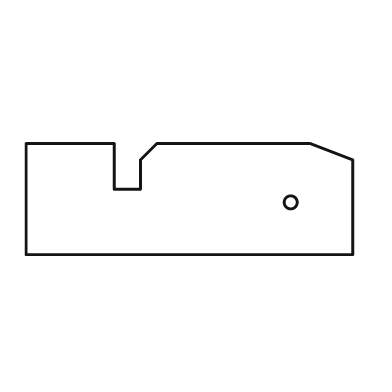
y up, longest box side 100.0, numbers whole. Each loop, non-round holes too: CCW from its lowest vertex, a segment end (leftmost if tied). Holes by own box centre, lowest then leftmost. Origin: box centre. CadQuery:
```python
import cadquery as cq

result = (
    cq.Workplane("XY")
    .moveTo(-50.0, -17.0)
    .lineTo(50.0, -17.0)
    .lineTo(50.0, 12.0)
    .lineTo(37.0, 17.0)
    .lineTo(-10.0, 17.0)
    .lineTo(-15.0, 12.0)
    .lineTo(-15.0, 3.0)
    .lineTo(-23.0, 3.0)
    .lineTo(-23.0, 17.0)
    .lineTo(-50.0, 17.0)
    .close()
    .moveTo(31.0, -1.0)
    .circle(2.0)
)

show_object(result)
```